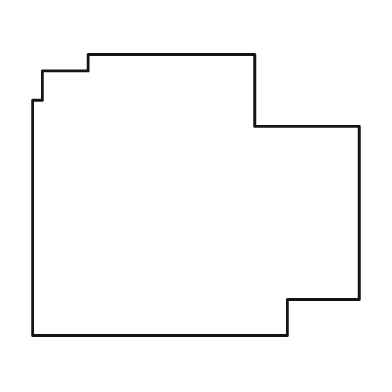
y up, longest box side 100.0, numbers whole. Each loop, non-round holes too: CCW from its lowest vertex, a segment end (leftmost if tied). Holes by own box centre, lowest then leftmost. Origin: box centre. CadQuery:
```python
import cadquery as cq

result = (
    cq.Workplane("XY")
    .moveTo(-50.0, -43.0)
    .lineTo(28.0, -43.0)
    .lineTo(28.0, -32.0)
    .lineTo(50.0, -32.0)
    .lineTo(50.0, 21.0)
    .lineTo(18.0, 21.0)
    .lineTo(18.0, 43.0)
    .lineTo(-33.0, 43.0)
    .lineTo(-33.0, 38.0)
    .lineTo(-47.0, 38.0)
    .lineTo(-47.0, 29.0)
    .lineTo(-50.0, 29.0)
    .close()
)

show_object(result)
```